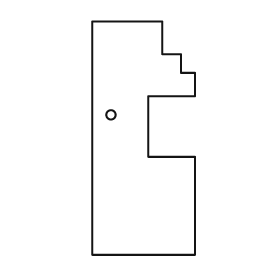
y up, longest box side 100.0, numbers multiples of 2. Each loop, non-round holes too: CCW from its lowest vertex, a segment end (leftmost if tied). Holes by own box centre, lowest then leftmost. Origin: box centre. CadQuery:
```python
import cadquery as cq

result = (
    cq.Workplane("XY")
    .moveTo(-22.0, -50.0)
    .lineTo(22.0, -50.0)
    .lineTo(22.0, -8.0)
    .lineTo(2.0, -8.0)
    .lineTo(2.0, 18.0)
    .lineTo(22.0, 18.0)
    .lineTo(22.0, 28.0)
    .lineTo(16.0, 28.0)
    .lineTo(16.0, 36.0)
    .lineTo(8.0, 36.0)
    .lineTo(8.0, 50.0)
    .lineTo(-22.0, 50.0)
    .close()
    .moveTo(-14.0, 10.0)
    .circle(2.0)
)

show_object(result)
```